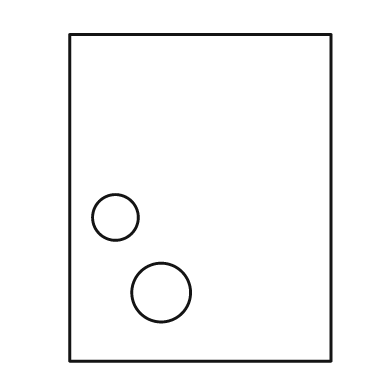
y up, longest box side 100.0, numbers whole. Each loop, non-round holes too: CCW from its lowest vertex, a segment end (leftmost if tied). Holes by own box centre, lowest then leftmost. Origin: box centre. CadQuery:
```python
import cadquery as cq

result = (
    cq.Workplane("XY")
    .moveTo(-40.0, -50.0)
    .lineTo(40.0, -50.0)
    .lineTo(40.0, 50.0)
    .lineTo(-40.0, 50.0)
    .close()
    .moveTo(-12.0, -29.0)
    .circle(9.0)
    .moveTo(-26.0, -6.0)
    .circle(7.0)
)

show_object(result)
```